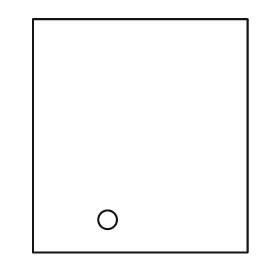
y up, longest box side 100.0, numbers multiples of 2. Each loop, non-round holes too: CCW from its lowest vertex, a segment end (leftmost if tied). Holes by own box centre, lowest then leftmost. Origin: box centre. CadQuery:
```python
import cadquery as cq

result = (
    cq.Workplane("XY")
    .moveTo(-46.0, -50.0)
    .lineTo(46.0, -50.0)
    .lineTo(46.0, 50.0)
    .lineTo(-46.0, 50.0)
    .close()
    .moveTo(-14.0, -36.0)
    .circle(4.0)
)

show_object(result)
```